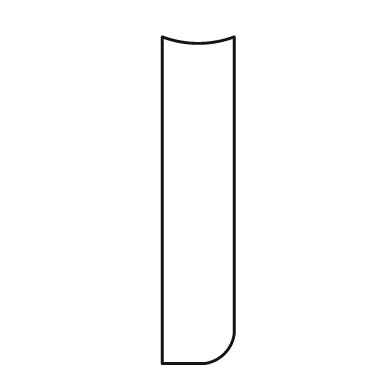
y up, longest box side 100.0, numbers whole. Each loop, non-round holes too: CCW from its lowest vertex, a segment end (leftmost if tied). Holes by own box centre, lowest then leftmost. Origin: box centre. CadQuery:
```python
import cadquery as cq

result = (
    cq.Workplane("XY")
    .moveTo(-11.0, -50.0)
    .lineTo(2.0, -50.0)
    .threePointArc((8.0, -47.0), (11.0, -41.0))
    .lineTo(11.0, 50.0)
    .threePointArc((0.0, 48.0), (-11.0, 50.0))
    .close()
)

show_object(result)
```